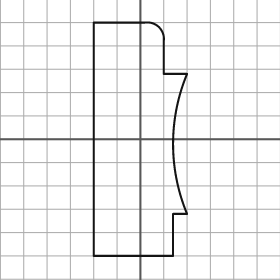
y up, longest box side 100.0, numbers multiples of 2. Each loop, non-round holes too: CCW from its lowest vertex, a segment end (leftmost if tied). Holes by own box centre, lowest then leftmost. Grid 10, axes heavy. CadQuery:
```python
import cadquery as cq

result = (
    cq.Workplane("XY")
    .moveTo(-20.0, -50.0)
    .lineTo(14.0, -50.0)
    .lineTo(14.0, -32.0)
    .lineTo(20.0, -32.0)
    .threePointArc((14.0, -2.0), (20.0, 28.0))
    .lineTo(10.0, 28.0)
    .lineTo(10.0, 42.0)
    .threePointArc((8.0, 48.0), (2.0, 50.0))
    .lineTo(-20.0, 50.0)
    .close()
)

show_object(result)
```